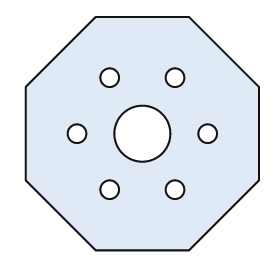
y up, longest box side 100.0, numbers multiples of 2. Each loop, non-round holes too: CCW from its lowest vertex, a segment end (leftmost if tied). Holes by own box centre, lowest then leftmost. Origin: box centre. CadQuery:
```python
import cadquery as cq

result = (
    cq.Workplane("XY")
    .moveTo(-20.0, -50.0)
    .lineTo(20.0, -50.0)
    .lineTo(50.0, -20.0)
    .lineTo(50.0, 20.0)
    .lineTo(20.0, 50.0)
    .lineTo(-20.0, 50.0)
    .lineTo(-50.0, 20.0)
    .lineTo(-50.0, -20.0)
    .close()
    .moveTo(-14.0, -24.0)
    .circle(4.0)
    .moveTo(14.0, -24.0)
    .circle(4.0)
    .moveTo(-28.0, 0.0)
    .circle(4.0)
    .moveTo(0.0, 0.0)
    .circle(12.0)
    .moveTo(28.0, 0.0)
    .circle(4.0)
    .moveTo(-14.0, 24.0)
    .circle(4.0)
    .moveTo(14.0, 24.0)
    .circle(4.0)
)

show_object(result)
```